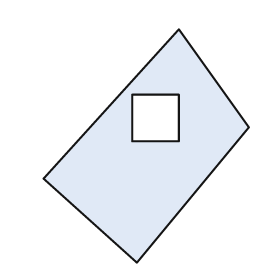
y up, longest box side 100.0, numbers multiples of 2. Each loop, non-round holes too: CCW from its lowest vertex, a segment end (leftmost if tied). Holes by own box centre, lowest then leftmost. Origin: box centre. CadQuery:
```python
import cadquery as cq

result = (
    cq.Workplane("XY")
    .moveTo(-4.0, -50.0)
    .lineTo(44.0, 8.0)
    .lineTo(14.0, 50.0)
    .lineTo(-44.0, -14.0)
    .close()
    .moveTo(-6.0, 2.0)
    .lineTo(14.0, 2.0)
    .lineTo(14.0, 22.0)
    .lineTo(-6.0, 22.0)
    .close()
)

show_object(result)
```